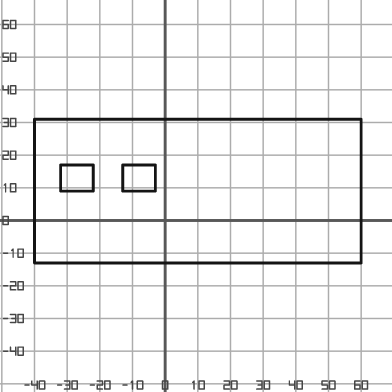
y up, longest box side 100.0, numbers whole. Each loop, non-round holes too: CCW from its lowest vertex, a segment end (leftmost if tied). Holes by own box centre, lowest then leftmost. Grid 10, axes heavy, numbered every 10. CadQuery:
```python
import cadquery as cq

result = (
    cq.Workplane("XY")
    .moveTo(-40.0, -13.0)
    .lineTo(60.0, -13.0)
    .lineTo(60.0, 31.0)
    .lineTo(-40.0, 31.0)
    .close()
    .moveTo(-32.0, 9.0)
    .lineTo(-22.0, 9.0)
    .lineTo(-22.0, 17.0)
    .lineTo(-32.0, 17.0)
    .close()
    .moveTo(-13.0, 9.0)
    .lineTo(-3.0, 9.0)
    .lineTo(-3.0, 17.0)
    .lineTo(-13.0, 17.0)
    .close()
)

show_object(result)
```